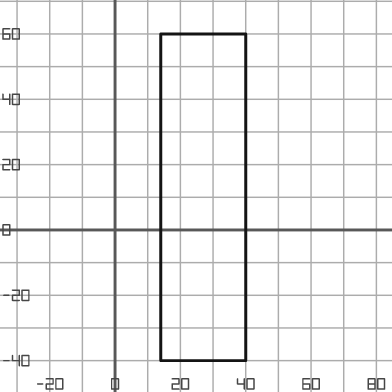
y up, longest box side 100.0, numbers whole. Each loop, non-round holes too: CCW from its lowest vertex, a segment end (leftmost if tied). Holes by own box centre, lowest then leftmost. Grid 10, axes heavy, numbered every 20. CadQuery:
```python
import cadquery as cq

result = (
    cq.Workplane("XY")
    .moveTo(14.0, -40.0)
    .lineTo(40.0, -40.0)
    .lineTo(40.0, 60.0)
    .lineTo(14.0, 60.0)
    .close()
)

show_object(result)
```